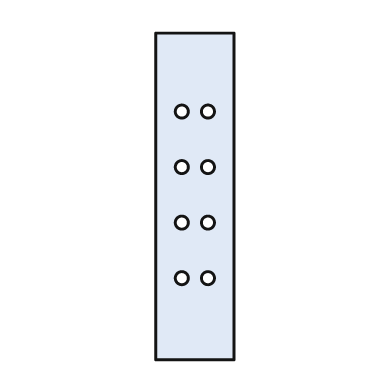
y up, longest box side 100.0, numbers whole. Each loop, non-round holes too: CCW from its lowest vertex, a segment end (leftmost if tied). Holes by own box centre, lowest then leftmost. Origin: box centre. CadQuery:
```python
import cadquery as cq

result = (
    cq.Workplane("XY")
    .moveTo(-12.0, -50.0)
    .lineTo(12.0, -50.0)
    .lineTo(12.0, 50.0)
    .lineTo(-12.0, 50.0)
    .close()
    .moveTo(-4.0, -25.0)
    .circle(2.0)
    .moveTo(4.0, -25.0)
    .circle(2.0)
    .moveTo(-4.0, -8.0)
    .circle(2.0)
    .moveTo(4.0, -8.0)
    .circle(2.0)
    .moveTo(-4.0, 9.0)
    .circle(2.0)
    .moveTo(4.0, 9.0)
    .circle(2.0)
    .moveTo(-4.0, 26.0)
    .circle(2.0)
    .moveTo(4.0, 26.0)
    .circle(2.0)
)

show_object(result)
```